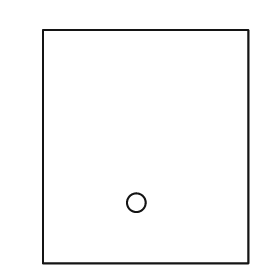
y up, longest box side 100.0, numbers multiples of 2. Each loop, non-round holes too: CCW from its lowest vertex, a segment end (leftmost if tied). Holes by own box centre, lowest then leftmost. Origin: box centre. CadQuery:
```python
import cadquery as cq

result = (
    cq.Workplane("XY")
    .moveTo(-44.0, -50.0)
    .lineTo(44.0, -50.0)
    .lineTo(44.0, 50.0)
    .lineTo(-44.0, 50.0)
    .close()
    .moveTo(-4.0, -24.0)
    .circle(4.0)
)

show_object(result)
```